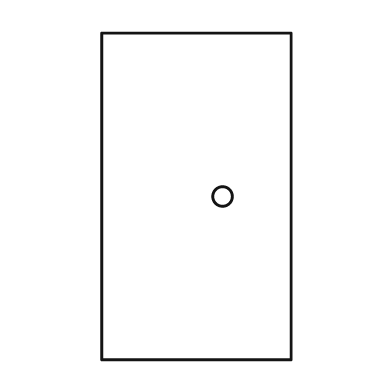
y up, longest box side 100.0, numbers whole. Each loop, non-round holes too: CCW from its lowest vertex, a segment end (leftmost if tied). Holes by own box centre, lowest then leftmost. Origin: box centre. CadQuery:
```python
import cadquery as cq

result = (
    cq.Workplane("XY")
    .moveTo(-29.0, -50.0)
    .lineTo(29.0, -50.0)
    .lineTo(29.0, 50.0)
    .lineTo(-29.0, 50.0)
    .close()
    .moveTo(8.0, 0.0)
    .circle(3.0)
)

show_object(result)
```